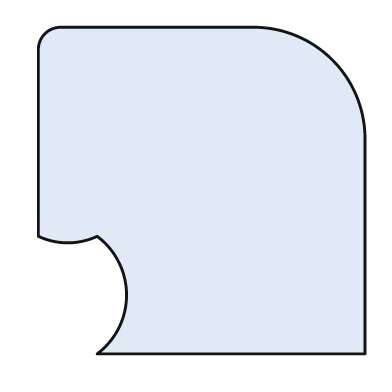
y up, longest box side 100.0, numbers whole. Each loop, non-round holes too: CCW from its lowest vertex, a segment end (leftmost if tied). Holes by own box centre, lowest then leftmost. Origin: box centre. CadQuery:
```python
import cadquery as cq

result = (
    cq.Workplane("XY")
    .moveTo(-32.0, -50.0)
    .lineTo(50.0, -50.0)
    .lineTo(50.0, 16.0)
    .threePointArc((40.0, 40.0), (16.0, 50.0))
    .lineTo(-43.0, 50.0)
    .threePointArc((-48.0, 48.0), (-50.0, 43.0))
    .lineTo(-50.0, -14.0)
    .threePointArc((-41.0, -16.0), (-32.0, -14.0))
    .threePointArc((-23.0, -32.0), (-32.0, -50.0))
    .close()
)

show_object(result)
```